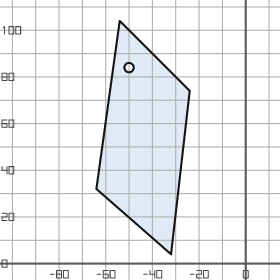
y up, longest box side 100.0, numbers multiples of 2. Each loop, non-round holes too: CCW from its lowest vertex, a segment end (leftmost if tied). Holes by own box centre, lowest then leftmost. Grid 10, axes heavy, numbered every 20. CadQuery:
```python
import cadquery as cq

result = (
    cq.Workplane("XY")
    .moveTo(-32.0, 4.0)
    .lineTo(-24.0, 74.0)
    .lineTo(-54.0, 104.0)
    .lineTo(-64.0, 32.0)
    .close()
    .moveTo(-50.0, 84.0)
    .circle(2.0)
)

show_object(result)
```